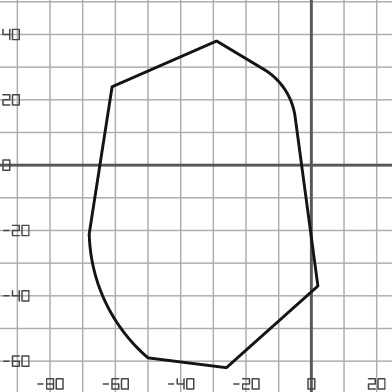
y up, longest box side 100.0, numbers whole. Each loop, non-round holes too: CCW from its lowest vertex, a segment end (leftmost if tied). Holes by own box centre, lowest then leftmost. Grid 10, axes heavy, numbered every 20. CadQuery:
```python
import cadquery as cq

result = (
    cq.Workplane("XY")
    .moveTo(-26.0, -62.0)
    .lineTo(2.0, -37.0)
    .lineTo(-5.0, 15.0)
    .threePointArc((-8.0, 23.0), (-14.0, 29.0))
    .lineTo(-29.0, 38.0)
    .lineTo(-61.0, 24.0)
    .lineTo(-68.0, -21.0)
    .threePointArc((-63.0, -42.0), (-50.0, -59.0))
    .close()
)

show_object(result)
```